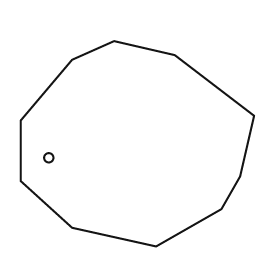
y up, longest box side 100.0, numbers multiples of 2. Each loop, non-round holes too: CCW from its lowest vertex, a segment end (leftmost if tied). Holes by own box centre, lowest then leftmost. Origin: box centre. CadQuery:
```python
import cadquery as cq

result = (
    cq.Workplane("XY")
    .moveTo(8.0, -44.0)
    .lineTo(36.0, -28.0)
    .lineTo(44.0, -14.0)
    .lineTo(50.0, 12.0)
    .lineTo(16.0, 38.0)
    .lineTo(-10.0, 44.0)
    .lineTo(-28.0, 36.0)
    .lineTo(-50.0, 10.0)
    .lineTo(-50.0, -16.0)
    .lineTo(-28.0, -36.0)
    .close()
    .moveTo(-38.0, -6.0)
    .circle(2.0)
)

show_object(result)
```